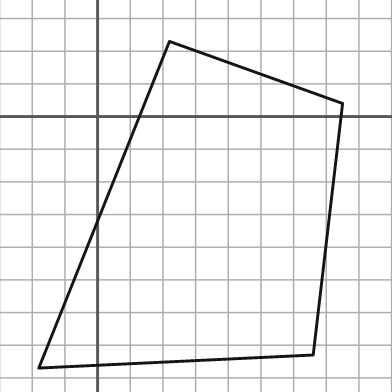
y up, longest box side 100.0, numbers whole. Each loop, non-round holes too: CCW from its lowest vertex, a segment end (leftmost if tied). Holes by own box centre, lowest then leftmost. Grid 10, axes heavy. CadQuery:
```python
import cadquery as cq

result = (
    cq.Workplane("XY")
    .moveTo(-18.0, -77.0)
    .lineTo(66.0, -73.0)
    .lineTo(75.0, 4.0)
    .lineTo(22.0, 23.0)
    .close()
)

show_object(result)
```